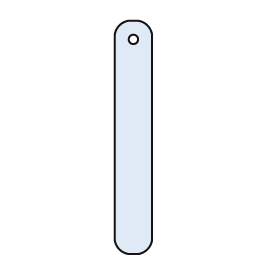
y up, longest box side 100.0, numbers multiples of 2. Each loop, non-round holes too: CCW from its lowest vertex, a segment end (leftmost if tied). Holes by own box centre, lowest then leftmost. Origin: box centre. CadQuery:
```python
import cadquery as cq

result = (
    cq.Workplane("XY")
    .moveTo(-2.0, -50.0)
    .lineTo(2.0, -50.0)
    .threePointArc((6.0, -48.0), (8.0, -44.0))
    .lineTo(8.0, 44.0)
    .threePointArc((6.0, 48.0), (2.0, 50.0))
    .lineTo(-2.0, 50.0)
    .threePointArc((-6.0, 48.0), (-8.0, 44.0))
    .lineTo(-8.0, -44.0)
    .threePointArc((-6.0, -48.0), (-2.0, -50.0))
    .close()
    .moveTo(0.0, 42.0)
    .circle(2.0)
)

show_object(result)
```